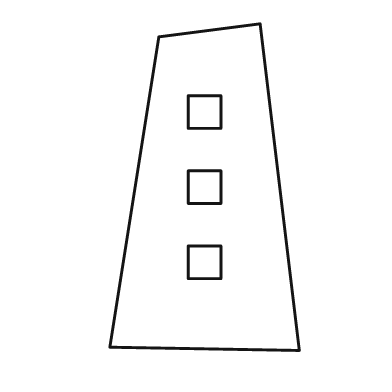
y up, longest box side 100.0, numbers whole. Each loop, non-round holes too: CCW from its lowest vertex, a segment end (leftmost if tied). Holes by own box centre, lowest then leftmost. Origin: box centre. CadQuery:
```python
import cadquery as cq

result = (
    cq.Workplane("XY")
    .moveTo(29.0, -50.0)
    .lineTo(17.0, 50.0)
    .lineTo(-14.0, 46.0)
    .lineTo(-29.0, -49.0)
    .close()
    .moveTo(-5.0, -28.0)
    .lineTo(5.0, -28.0)
    .lineTo(5.0, -18.0)
    .lineTo(-5.0, -18.0)
    .close()
    .moveTo(-5.0, -5.0)
    .lineTo(5.0, -5.0)
    .lineTo(5.0, 5.0)
    .lineTo(-5.0, 5.0)
    .close()
    .moveTo(-5.0, 18.0)
    .lineTo(5.0, 18.0)
    .lineTo(5.0, 28.0)
    .lineTo(-5.0, 28.0)
    .close()
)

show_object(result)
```